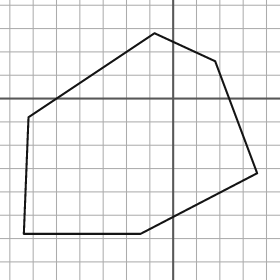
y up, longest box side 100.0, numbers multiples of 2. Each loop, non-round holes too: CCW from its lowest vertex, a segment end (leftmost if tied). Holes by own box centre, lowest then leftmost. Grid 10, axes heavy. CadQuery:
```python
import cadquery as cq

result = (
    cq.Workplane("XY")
    .moveTo(-64.0, -58.0)
    .lineTo(-14.0, -58.0)
    .lineTo(36.0, -32.0)
    .lineTo(18.0, 16.0)
    .lineTo(-8.0, 28.0)
    .lineTo(-62.0, -8.0)
    .close()
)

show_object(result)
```